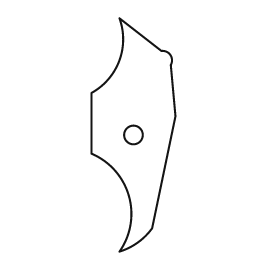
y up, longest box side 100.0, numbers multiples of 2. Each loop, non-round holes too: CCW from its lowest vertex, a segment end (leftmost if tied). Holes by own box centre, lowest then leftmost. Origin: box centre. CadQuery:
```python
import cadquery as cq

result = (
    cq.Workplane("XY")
    .moveTo(-6.0, -50.0)
    .threePointArc((2.0, -46.0), (8.0, -40.0))
    .lineTo(18.0, 8.0)
    .lineTo(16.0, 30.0)
    .threePointArc((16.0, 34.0), (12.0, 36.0))
    .lineTo(-6.0, 50.0)
    .threePointArc((-6.0, 32.0), (-18.0, 18.0))
    .lineTo(-18.0, -8.0)
    .threePointArc((-2.0, -26.0), (-6.0, -50.0))
    .close()
    .moveTo(0.0, 0.0)
    .circle(4.0)
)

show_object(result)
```